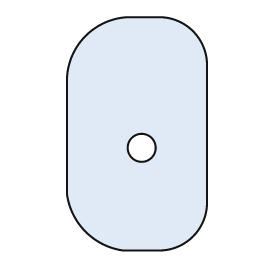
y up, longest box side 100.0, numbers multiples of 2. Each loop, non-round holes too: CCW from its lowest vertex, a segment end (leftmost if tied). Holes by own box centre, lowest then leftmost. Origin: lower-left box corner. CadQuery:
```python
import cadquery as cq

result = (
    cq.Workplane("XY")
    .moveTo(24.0, 0.0)
    .lineTo(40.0, 0.0)
    .threePointArc((54.0, 6.0), (60.0, 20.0))
    .lineTo(60.0, 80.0)
    .threePointArc((54.0, 94.0), (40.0, 100.0))
    .lineTo(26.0, 100.0)
    .threePointArc((8.0, 92.0), (0.0, 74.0))
    .lineTo(0.0, 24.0)
    .threePointArc((8.0, 8.0), (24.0, 0.0))
    .close()
    .moveTo(32.0, 44.0)
    .circle(6.0)
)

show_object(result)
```